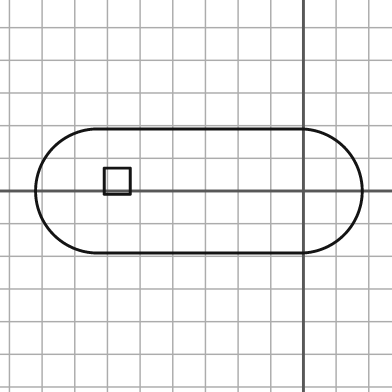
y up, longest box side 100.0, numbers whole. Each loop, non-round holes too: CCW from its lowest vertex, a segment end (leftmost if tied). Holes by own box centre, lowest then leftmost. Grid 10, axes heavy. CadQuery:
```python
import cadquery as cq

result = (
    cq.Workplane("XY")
    .moveTo(-63.0, -19.0)
    .lineTo(-1.0, -19.0)
    .threePointArc((18.0, 0.0), (-1.0, 19.0))
    .lineTo(-63.0, 19.0)
    .threePointArc((-82.0, 0.0), (-63.0, -19.0))
    .close()
    .moveTo(-61.0, -1.0)
    .lineTo(-53.0, -1.0)
    .lineTo(-53.0, 7.0)
    .lineTo(-61.0, 7.0)
    .close()
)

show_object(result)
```